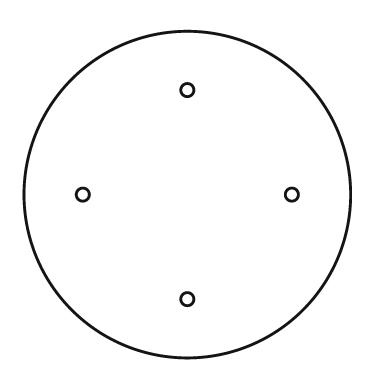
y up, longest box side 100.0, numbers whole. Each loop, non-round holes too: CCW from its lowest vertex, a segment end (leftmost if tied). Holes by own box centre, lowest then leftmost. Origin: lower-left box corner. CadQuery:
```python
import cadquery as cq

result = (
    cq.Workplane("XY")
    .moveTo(50.0, 50.0)
    .circle(50.0)
    .moveTo(50.0, 18.0)
    .circle(2.0)
    .moveTo(18.0, 50.0)
    .circle(2.0)
    .moveTo(82.0, 50.0)
    .circle(2.0)
    .moveTo(50.0, 82.0)
    .circle(2.0)
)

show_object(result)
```